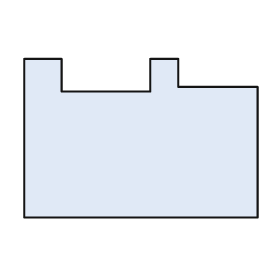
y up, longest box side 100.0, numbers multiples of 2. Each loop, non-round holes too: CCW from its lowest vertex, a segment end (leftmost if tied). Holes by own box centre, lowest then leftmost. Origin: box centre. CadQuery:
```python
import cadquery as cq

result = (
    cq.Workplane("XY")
    .moveTo(-50.0, -34.0)
    .lineTo(50.0, -34.0)
    .lineTo(50.0, 22.0)
    .lineTo(16.0, 22.0)
    .lineTo(16.0, 34.0)
    .lineTo(4.0, 34.0)
    .lineTo(4.0, 20.0)
    .lineTo(-34.0, 20.0)
    .lineTo(-34.0, 34.0)
    .lineTo(-50.0, 34.0)
    .close()
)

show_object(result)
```